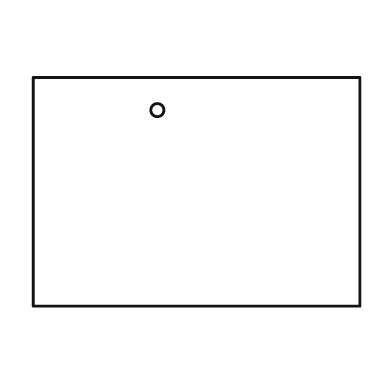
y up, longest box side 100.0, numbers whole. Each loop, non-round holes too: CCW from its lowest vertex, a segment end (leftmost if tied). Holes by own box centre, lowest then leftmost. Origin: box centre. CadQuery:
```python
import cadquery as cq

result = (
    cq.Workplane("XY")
    .moveTo(-50.0, -35.0)
    .lineTo(50.0, -35.0)
    .lineTo(50.0, 35.0)
    .lineTo(-50.0, 35.0)
    .close()
    .moveTo(-12.0, 25.0)
    .circle(2.0)
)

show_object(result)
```